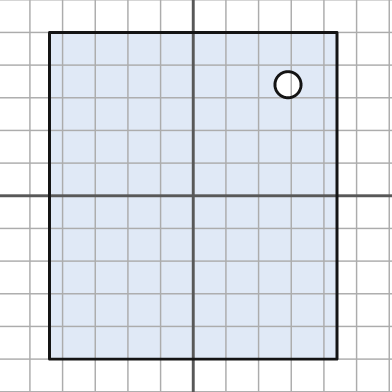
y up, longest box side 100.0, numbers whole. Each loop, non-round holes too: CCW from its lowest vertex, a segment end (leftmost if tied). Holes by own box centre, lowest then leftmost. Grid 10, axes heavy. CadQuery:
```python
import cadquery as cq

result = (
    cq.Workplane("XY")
    .moveTo(-44.0, -50.0)
    .lineTo(44.0, -50.0)
    .lineTo(44.0, 50.0)
    .lineTo(-44.0, 50.0)
    .close()
    .moveTo(29.0, 34.0)
    .circle(4.0)
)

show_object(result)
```